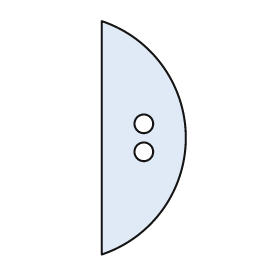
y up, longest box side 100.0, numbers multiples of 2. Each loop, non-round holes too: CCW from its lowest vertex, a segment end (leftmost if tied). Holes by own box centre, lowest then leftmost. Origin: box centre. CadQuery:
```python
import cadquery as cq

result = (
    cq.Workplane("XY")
    .moveTo(-18.0, -50.0)
    .threePointArc((18.0, 0.0), (-18.0, 50.0))
    .close()
    .moveTo(0.0, -6.0)
    .circle(4.0)
    .moveTo(0.0, 6.0)
    .circle(4.0)
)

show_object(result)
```